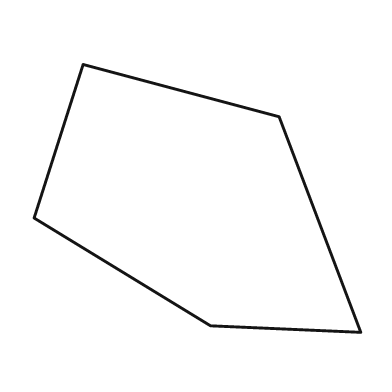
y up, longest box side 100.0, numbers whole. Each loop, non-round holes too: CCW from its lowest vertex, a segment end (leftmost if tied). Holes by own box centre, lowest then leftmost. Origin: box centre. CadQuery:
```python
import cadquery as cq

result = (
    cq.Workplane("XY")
    .moveTo(50.0, -41.0)
    .lineTo(25.0, 25.0)
    .lineTo(-35.0, 41.0)
    .lineTo(-50.0, -6.0)
    .lineTo(4.0, -39.0)
    .close()
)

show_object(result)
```